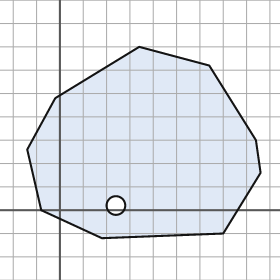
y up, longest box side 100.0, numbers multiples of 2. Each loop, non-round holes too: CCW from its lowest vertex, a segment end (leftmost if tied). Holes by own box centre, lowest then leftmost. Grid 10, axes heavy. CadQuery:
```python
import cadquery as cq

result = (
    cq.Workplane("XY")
    .moveTo(18.0, -12.0)
    .lineTo(70.0, -10.0)
    .lineTo(86.0, 16.0)
    .lineTo(84.0, 30.0)
    .lineTo(64.0, 62.0)
    .lineTo(34.0, 70.0)
    .lineTo(-2.0, 48.0)
    .lineTo(-14.0, 26.0)
    .lineTo(-8.0, 0.0)
    .close()
    .moveTo(24.0, 2.0)
    .circle(4.0)
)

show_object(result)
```